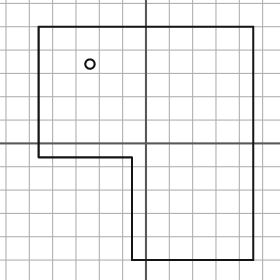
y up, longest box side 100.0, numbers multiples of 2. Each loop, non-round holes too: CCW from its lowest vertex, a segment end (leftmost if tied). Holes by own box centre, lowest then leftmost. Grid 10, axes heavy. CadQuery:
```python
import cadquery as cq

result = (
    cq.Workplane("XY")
    .moveTo(-6.0, -50.0)
    .lineTo(46.0, -50.0)
    .lineTo(46.0, 50.0)
    .lineTo(-46.0, 50.0)
    .lineTo(-46.0, -6.0)
    .lineTo(-6.0, -6.0)
    .close()
    .moveTo(-24.0, 34.0)
    .circle(2.0)
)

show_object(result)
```